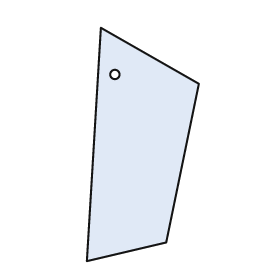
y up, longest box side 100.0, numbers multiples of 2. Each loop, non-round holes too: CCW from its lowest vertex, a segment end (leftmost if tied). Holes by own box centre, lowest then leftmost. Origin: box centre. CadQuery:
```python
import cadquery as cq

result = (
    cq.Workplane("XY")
    .moveTo(-24.0, -50.0)
    .lineTo(10.0, -42.0)
    .lineTo(24.0, 26.0)
    .lineTo(-18.0, 50.0)
    .close()
    .moveTo(-12.0, 30.0)
    .circle(2.0)
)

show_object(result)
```